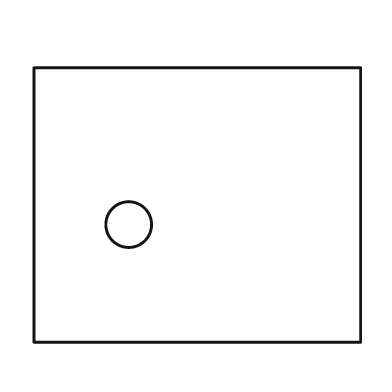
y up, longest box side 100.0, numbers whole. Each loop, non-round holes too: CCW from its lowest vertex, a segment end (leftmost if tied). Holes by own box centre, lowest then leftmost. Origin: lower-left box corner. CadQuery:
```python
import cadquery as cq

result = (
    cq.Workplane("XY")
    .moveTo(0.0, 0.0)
    .lineTo(100.0, 0.0)
    .lineTo(100.0, 84.0)
    .lineTo(0.0, 84.0)
    .close()
    .moveTo(29.0, 36.0)
    .circle(7.0)
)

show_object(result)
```